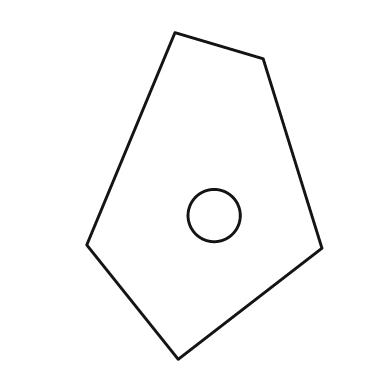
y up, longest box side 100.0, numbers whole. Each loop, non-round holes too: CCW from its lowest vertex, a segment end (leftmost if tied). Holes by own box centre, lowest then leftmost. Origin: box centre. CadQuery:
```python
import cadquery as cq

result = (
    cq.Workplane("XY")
    .moveTo(-8.0, -50.0)
    .lineTo(36.0, -16.0)
    .lineTo(18.0, 42.0)
    .lineTo(-9.0, 50.0)
    .lineTo(-36.0, -15.0)
    .close()
    .moveTo(3.0, -6.0)
    .circle(8.0)
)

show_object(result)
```